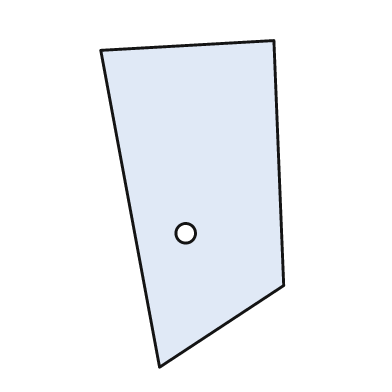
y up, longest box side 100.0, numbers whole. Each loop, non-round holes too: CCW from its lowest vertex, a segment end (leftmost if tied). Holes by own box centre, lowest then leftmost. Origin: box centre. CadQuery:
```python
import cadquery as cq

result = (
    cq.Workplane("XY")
    .moveTo(-10.0, -50.0)
    .lineTo(28.0, -25.0)
    .lineTo(25.0, 50.0)
    .lineTo(-28.0, 47.0)
    .close()
    .moveTo(-2.0, -9.0)
    .circle(3.0)
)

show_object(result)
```